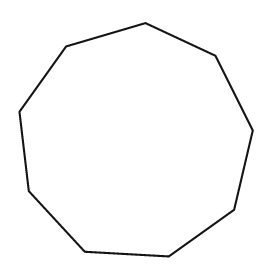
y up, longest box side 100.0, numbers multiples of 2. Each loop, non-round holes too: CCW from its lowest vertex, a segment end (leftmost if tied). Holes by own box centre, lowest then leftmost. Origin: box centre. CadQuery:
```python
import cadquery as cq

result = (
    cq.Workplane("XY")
    .moveTo(14.0, -50.0)
    .lineTo(42.0, -30.0)
    .lineTo(50.0, 4.0)
    .lineTo(34.0, 36.0)
    .lineTo(4.0, 50.0)
    .lineTo(-30.0, 40.0)
    .lineTo(-50.0, 12.0)
    .lineTo(-46.0, -22.0)
    .lineTo(-22.0, -48.0)
    .close()
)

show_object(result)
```